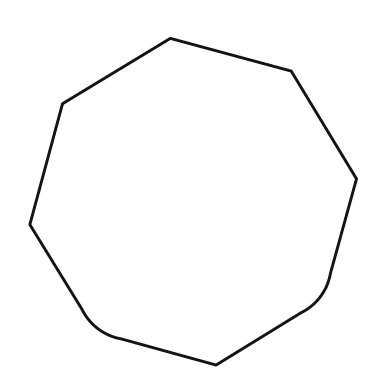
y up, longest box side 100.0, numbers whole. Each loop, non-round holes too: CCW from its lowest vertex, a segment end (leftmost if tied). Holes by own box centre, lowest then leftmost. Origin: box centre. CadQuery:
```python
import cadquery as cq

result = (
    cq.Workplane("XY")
    .moveTo(7.0, -50.0)
    .lineTo(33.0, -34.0)
    .threePointArc((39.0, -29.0), (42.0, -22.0))
    .lineTo(50.0, 7.0)
    .lineTo(30.0, 40.0)
    .lineTo(-7.0, 50.0)
    .lineTo(-40.0, 30.0)
    .lineTo(-50.0, -7.0)
    .lineTo(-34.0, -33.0)
    .threePointArc((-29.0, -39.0), (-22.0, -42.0))
    .close()
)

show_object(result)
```